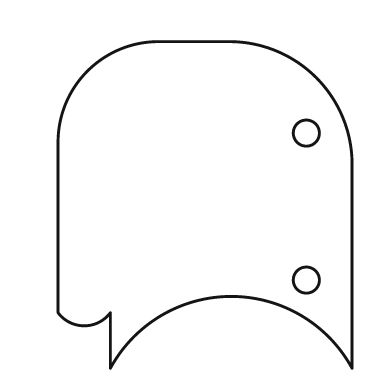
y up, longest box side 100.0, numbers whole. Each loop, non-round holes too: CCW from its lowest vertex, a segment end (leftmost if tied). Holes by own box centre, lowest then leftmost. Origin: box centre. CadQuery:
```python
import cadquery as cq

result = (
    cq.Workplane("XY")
    .moveTo(-29.0, -50.0)
    .threePointArc((8.0, -28.0), (45.0, -50.0))
    .lineTo(45.0, 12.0)
    .threePointArc((34.0, 39.0), (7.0, 50.0))
    .lineTo(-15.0, 50.0)
    .threePointArc((-36.0, 41.0), (-45.0, 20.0))
    .lineTo(-45.0, -33.0)
    .threePointArc((-37.0, -37.0), (-29.0, -33.0))
    .close()
    .moveTo(31.0, -23.0)
    .circle(4.0)
    .moveTo(31.0, 22.0)
    .circle(4.0)
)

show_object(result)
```